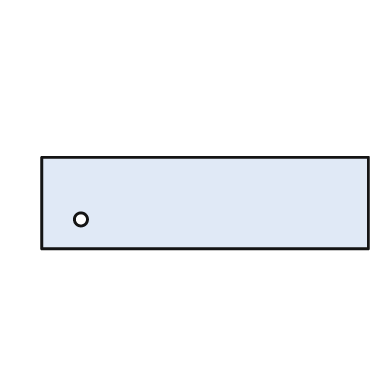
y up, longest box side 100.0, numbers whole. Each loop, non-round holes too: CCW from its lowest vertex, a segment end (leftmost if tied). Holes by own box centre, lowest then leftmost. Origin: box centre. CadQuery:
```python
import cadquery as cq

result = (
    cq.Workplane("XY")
    .moveTo(-50.0, -14.0)
    .lineTo(50.0, -14.0)
    .lineTo(50.0, 14.0)
    .lineTo(-50.0, 14.0)
    .close()
    .moveTo(-38.0, -5.0)
    .circle(2.0)
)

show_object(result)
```